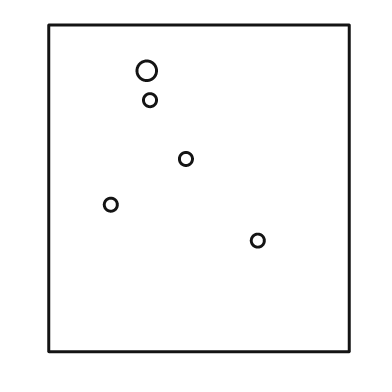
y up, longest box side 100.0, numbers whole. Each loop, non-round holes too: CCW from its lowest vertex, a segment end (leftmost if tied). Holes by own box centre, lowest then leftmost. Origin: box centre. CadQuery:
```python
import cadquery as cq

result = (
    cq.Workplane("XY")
    .moveTo(-46.0, -50.0)
    .lineTo(46.0, -50.0)
    .lineTo(46.0, 50.0)
    .lineTo(-46.0, 50.0)
    .close()
    .moveTo(18.0, -16.0)
    .circle(2.0)
    .moveTo(-27.0, -5.0)
    .circle(2.0)
    .moveTo(-4.0, 9.0)
    .circle(2.0)
    .moveTo(-15.0, 27.0)
    .circle(2.0)
    .moveTo(-16.0, 36.0)
    .circle(3.0)
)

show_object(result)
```